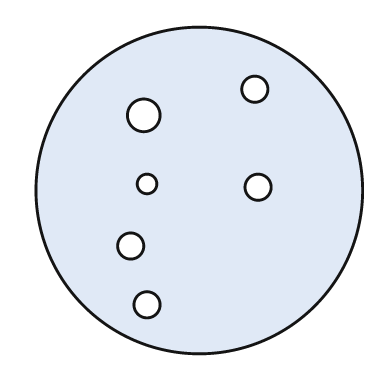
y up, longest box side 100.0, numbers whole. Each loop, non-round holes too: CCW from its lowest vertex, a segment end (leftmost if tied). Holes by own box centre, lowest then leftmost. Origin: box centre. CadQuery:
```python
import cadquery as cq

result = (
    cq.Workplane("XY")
    .moveTo(0.0, 0.0)
    .circle(50.0)
    .moveTo(-16.0, -35.0)
    .circle(4.0)
    .moveTo(-21.0, -17.0)
    .circle(4.0)
    .moveTo(18.0, 1.0)
    .circle(4.0)
    .moveTo(-16.0, 2.0)
    .circle(3.0)
    .moveTo(-17.0, 23.0)
    .circle(5.0)
    .moveTo(17.0, 31.0)
    .circle(4.0)
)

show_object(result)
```